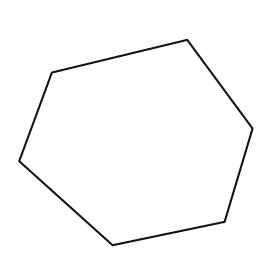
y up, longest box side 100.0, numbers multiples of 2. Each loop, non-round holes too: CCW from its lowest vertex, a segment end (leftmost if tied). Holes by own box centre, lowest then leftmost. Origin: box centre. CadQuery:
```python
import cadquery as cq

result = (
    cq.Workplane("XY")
    .moveTo(-10.0, -44.0)
    .lineTo(38.0, -34.0)
    .lineTo(50.0, 6.0)
    .lineTo(22.0, 44.0)
    .lineTo(-36.0, 30.0)
    .lineTo(-50.0, -8.0)
    .close()
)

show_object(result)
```